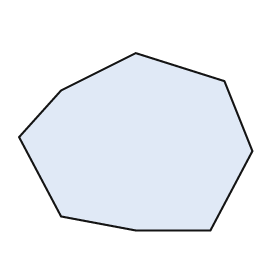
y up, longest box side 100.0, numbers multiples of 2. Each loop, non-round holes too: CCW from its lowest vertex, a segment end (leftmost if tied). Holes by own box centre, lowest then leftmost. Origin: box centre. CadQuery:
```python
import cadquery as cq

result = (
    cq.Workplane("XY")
    .moveTo(0.0, -38.0)
    .lineTo(32.0, -38.0)
    .lineTo(50.0, -4.0)
    .lineTo(38.0, 26.0)
    .lineTo(0.0, 38.0)
    .lineTo(-32.0, 22.0)
    .lineTo(-50.0, 2.0)
    .lineTo(-32.0, -32.0)
    .close()
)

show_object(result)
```